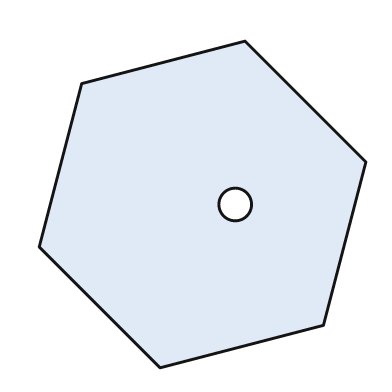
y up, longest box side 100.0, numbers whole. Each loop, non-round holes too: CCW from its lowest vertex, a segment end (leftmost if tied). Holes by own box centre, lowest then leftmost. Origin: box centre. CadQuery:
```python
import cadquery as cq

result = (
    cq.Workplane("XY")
    .moveTo(-13.0, -50.0)
    .lineTo(37.0, -37.0)
    .lineTo(50.0, 13.0)
    .lineTo(13.0, 50.0)
    .lineTo(-37.0, 37.0)
    .lineTo(-50.0, -13.0)
    .close()
    .moveTo(10.0, 0.0)
    .circle(5.0)
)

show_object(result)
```